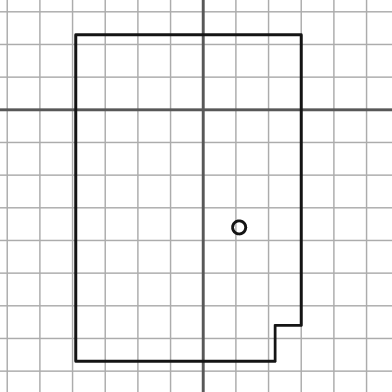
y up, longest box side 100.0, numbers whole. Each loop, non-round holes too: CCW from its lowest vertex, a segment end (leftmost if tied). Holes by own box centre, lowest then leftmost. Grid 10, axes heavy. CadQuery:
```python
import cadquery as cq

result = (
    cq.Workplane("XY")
    .moveTo(-39.0, -77.0)
    .lineTo(22.0, -77.0)
    .lineTo(22.0, -66.0)
    .lineTo(30.0, -66.0)
    .lineTo(30.0, 23.0)
    .lineTo(-39.0, 23.0)
    .close()
    .moveTo(11.0, -36.0)
    .circle(2.0)
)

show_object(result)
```